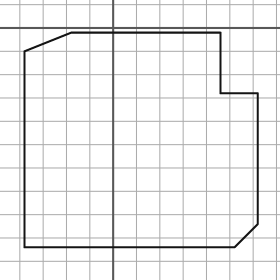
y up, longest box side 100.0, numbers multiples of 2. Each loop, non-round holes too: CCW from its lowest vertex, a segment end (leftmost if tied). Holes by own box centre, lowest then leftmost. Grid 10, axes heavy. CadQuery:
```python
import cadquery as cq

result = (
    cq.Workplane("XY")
    .moveTo(-38.0, -94.0)
    .lineTo(52.0, -94.0)
    .lineTo(62.0, -84.0)
    .lineTo(62.0, -28.0)
    .lineTo(46.0, -28.0)
    .lineTo(46.0, -2.0)
    .lineTo(-18.0, -2.0)
    .lineTo(-38.0, -10.0)
    .close()
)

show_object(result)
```